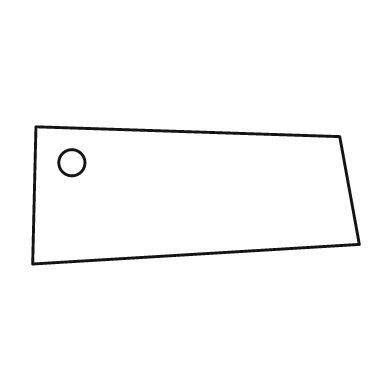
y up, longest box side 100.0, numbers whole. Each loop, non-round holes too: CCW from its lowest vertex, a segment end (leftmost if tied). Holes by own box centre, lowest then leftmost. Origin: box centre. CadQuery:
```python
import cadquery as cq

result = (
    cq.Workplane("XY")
    .moveTo(-50.0, -21.0)
    .lineTo(50.0, -15.0)
    .lineTo(44.0, 18.0)
    .lineTo(-49.0, 21.0)
    .close()
    .moveTo(-38.0, 10.0)
    .circle(4.0)
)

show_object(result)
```